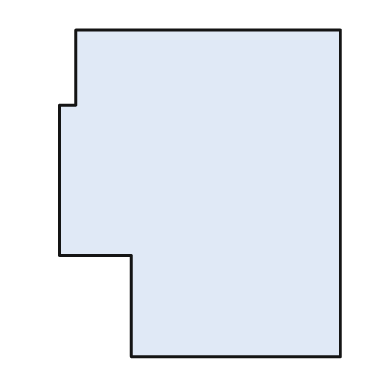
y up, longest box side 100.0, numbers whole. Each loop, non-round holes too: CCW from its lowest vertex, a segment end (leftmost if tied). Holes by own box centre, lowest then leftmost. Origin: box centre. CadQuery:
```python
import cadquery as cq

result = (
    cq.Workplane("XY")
    .moveTo(-21.0, -50.0)
    .lineTo(43.0, -50.0)
    .lineTo(43.0, 50.0)
    .lineTo(-38.0, 50.0)
    .lineTo(-38.0, 27.0)
    .lineTo(-43.0, 27.0)
    .lineTo(-43.0, -19.0)
    .lineTo(-21.0, -19.0)
    .close()
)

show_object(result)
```